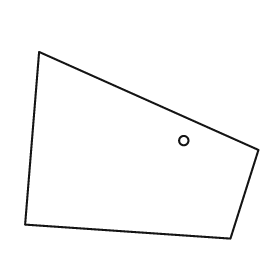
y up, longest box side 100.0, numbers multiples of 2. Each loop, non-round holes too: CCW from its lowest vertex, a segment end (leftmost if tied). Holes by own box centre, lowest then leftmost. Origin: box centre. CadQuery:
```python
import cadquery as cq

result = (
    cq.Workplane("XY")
    .moveTo(38.0, -40.0)
    .lineTo(50.0, -2.0)
    .lineTo(-44.0, 40.0)
    .lineTo(-50.0, -34.0)
    .close()
    .moveTo(18.0, 2.0)
    .circle(2.0)
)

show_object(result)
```